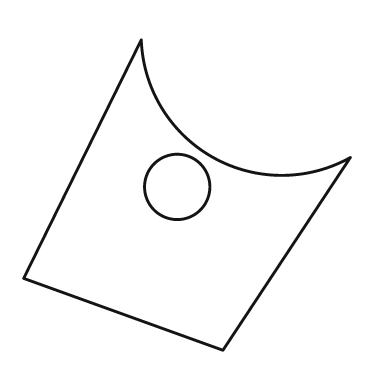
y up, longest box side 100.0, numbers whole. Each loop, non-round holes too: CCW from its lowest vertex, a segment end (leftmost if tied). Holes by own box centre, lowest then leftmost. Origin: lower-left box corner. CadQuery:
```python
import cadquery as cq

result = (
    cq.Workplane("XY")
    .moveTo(61.0, 0.0)
    .lineTo(100.0, 59.0)
    .threePointArc((58.0, 59.0), (36.0, 95.0))
    .lineTo(0.0, 22.0)
    .close()
    .moveTo(47.0, 50.0)
    .circle(10.0)
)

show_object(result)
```